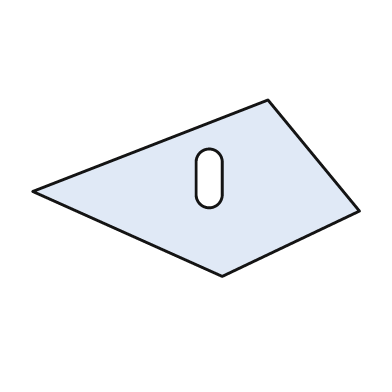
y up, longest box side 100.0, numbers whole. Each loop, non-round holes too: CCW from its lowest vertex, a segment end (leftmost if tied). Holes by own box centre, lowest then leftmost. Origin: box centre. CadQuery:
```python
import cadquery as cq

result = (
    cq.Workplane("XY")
    .moveTo(8.0, -27.0)
    .lineTo(50.0, -7.0)
    .lineTo(22.0, 27.0)
    .lineTo(-50.0, -1.0)
    .close()
    .moveTo(0.0, -2.0)
    .threePointArc((4.0, -6.0), (8.0, -2.0))
    .lineTo(8.0, 8.0)
    .threePointArc((4.0, 12.0), (0.0, 8.0))
    .close()
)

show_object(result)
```